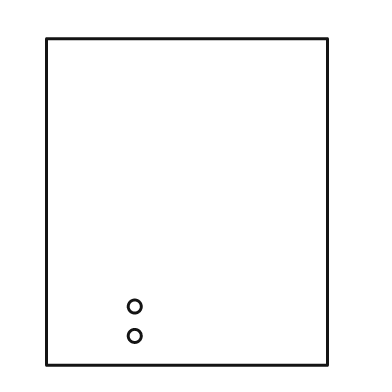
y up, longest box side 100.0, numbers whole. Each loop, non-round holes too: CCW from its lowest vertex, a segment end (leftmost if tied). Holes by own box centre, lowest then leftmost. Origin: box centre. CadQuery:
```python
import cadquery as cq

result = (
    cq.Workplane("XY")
    .moveTo(-43.0, -50.0)
    .lineTo(43.0, -50.0)
    .lineTo(43.0, 50.0)
    .lineTo(-43.0, 50.0)
    .close()
    .moveTo(-16.0, -41.0)
    .circle(2.0)
    .moveTo(-16.0, -32.0)
    .circle(2.0)
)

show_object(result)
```